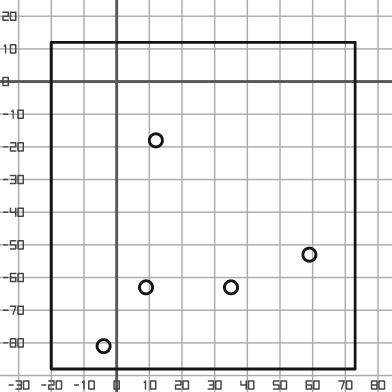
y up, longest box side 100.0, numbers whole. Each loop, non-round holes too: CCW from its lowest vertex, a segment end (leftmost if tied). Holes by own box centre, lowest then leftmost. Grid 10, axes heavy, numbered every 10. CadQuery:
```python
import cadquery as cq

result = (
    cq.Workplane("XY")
    .moveTo(-20.0, -88.0)
    .lineTo(73.0, -88.0)
    .lineTo(73.0, 12.0)
    .lineTo(-20.0, 12.0)
    .close()
    .moveTo(-4.0, -81.0)
    .circle(2.0)
    .moveTo(9.0, -63.0)
    .circle(2.0)
    .moveTo(35.0, -63.0)
    .circle(2.0)
    .moveTo(59.0, -53.0)
    .circle(2.0)
    .moveTo(12.0, -18.0)
    .circle(2.0)
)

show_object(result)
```